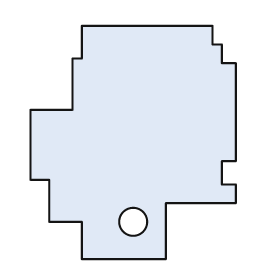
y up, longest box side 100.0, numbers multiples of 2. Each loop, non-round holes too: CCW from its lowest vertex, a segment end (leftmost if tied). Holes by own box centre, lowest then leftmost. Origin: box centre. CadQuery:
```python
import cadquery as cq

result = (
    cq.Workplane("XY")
    .moveTo(-22.0, -50.0)
    .lineTo(14.0, -50.0)
    .lineTo(14.0, -26.0)
    .lineTo(44.0, -26.0)
    .lineTo(44.0, -18.0)
    .lineTo(38.0, -18.0)
    .lineTo(38.0, -8.0)
    .lineTo(44.0, -8.0)
    .lineTo(44.0, 34.0)
    .lineTo(38.0, 34.0)
    .lineTo(38.0, 42.0)
    .lineTo(34.0, 42.0)
    .lineTo(34.0, 50.0)
    .lineTo(-22.0, 50.0)
    .lineTo(-22.0, 36.0)
    .lineTo(-26.0, 36.0)
    .lineTo(-26.0, 14.0)
    .lineTo(-44.0, 14.0)
    .lineTo(-44.0, -16.0)
    .lineTo(-36.0, -16.0)
    .lineTo(-36.0, -34.0)
    .lineTo(-22.0, -34.0)
    .close()
    .moveTo(0.0, -34.0)
    .circle(6.0)
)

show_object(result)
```